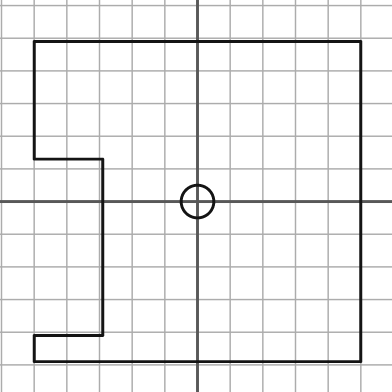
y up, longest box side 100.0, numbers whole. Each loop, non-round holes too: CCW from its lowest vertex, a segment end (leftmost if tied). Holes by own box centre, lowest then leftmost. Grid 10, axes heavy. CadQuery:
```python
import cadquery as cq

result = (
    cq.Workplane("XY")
    .moveTo(-50.0, -49.0)
    .lineTo(50.0, -49.0)
    .lineTo(50.0, 49.0)
    .lineTo(-50.0, 49.0)
    .lineTo(-50.0, 13.0)
    .lineTo(-29.0, 13.0)
    .lineTo(-29.0, -41.0)
    .lineTo(-50.0, -41.0)
    .close()
    .moveTo(0.0, 0.0)
    .circle(5.0)
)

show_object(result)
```